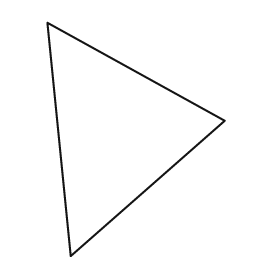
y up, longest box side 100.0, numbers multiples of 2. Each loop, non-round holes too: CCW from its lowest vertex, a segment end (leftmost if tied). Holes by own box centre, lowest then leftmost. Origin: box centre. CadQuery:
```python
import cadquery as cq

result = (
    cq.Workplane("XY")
    .moveTo(-28.0, -50.0)
    .lineTo(38.0, 8.0)
    .lineTo(-38.0, 50.0)
    .close()
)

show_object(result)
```